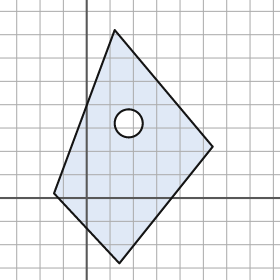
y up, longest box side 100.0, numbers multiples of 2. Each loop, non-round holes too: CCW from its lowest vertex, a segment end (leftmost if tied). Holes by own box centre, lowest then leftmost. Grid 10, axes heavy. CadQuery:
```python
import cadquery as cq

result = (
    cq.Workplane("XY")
    .moveTo(14.0, -28.0)
    .lineTo(54.0, 22.0)
    .lineTo(12.0, 72.0)
    .lineTo(-14.0, 2.0)
    .close()
    .moveTo(18.0, 32.0)
    .circle(6.0)
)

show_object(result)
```